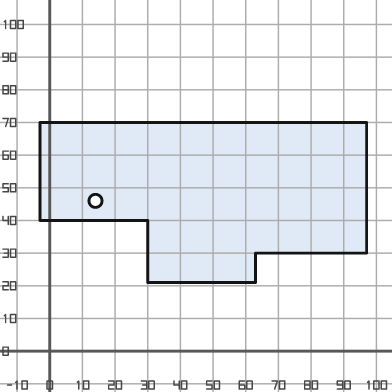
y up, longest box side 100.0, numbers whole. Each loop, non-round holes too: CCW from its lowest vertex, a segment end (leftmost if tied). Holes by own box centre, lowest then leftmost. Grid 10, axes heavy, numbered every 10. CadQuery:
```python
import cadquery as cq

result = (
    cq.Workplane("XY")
    .moveTo(30.0, 21.0)
    .lineTo(63.0, 21.0)
    .lineTo(63.0, 30.0)
    .lineTo(97.0, 30.0)
    .lineTo(97.0, 70.0)
    .lineTo(-3.0, 70.0)
    .lineTo(-3.0, 40.0)
    .lineTo(30.0, 40.0)
    .close()
    .moveTo(14.0, 46.0)
    .circle(2.0)
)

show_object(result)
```